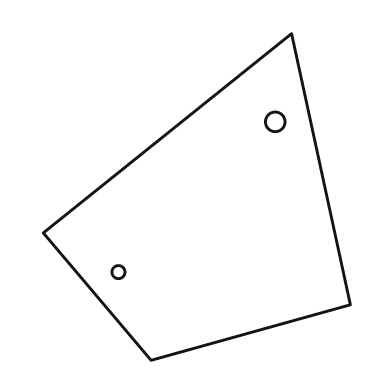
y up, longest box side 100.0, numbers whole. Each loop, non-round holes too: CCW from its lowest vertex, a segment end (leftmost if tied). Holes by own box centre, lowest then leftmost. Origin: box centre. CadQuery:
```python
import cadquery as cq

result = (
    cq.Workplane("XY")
    .moveTo(-14.0, -50.0)
    .lineTo(47.0, -33.0)
    .lineTo(29.0, 50.0)
    .lineTo(-47.0, -11.0)
    .close()
    .moveTo(-24.0, -23.0)
    .circle(2.0)
    .moveTo(24.0, 23.0)
    .circle(3.0)
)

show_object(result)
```